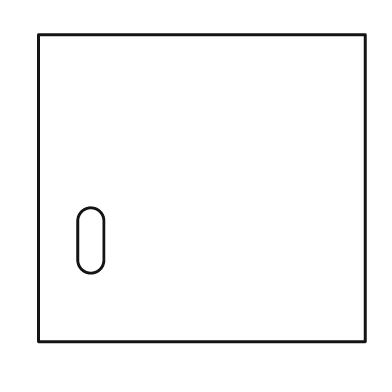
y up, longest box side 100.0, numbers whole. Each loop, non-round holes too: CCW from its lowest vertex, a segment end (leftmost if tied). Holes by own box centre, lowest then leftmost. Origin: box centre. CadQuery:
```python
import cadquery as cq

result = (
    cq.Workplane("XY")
    .moveTo(-50.0, -47.0)
    .lineTo(50.0, -47.0)
    .lineTo(50.0, 47.0)
    .lineTo(-50.0, 47.0)
    .close()
    .moveTo(-38.0, -22.0)
    .threePointArc((-34.0, -26.0), (-30.0, -22.0))
    .lineTo(-30.0, -10.0)
    .threePointArc((-34.0, -6.0), (-38.0, -10.0))
    .close()
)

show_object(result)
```